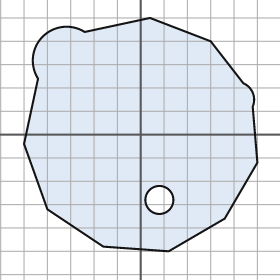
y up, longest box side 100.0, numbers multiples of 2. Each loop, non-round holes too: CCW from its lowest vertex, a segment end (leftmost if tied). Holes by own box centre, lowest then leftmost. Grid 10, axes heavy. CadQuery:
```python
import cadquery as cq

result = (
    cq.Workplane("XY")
    .moveTo(12.0, -50.0)
    .lineTo(36.0, -36.0)
    .lineTo(50.0, -12.0)
    .lineTo(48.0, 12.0)
    .threePointArc((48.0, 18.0), (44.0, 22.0))
    .lineTo(30.0, 40.0)
    .lineTo(4.0, 50.0)
    .lineTo(-24.0, 44.0)
    .threePointArc((-42.0, 42.0), (-44.0, 24.0))
    .lineTo(-50.0, -4.0)
    .lineTo(-40.0, -32.0)
    .lineTo(-16.0, -48.0)
    .close()
    .moveTo(8.0, -28.0)
    .circle(6.0)
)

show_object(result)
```